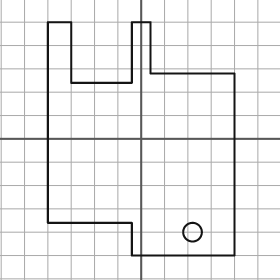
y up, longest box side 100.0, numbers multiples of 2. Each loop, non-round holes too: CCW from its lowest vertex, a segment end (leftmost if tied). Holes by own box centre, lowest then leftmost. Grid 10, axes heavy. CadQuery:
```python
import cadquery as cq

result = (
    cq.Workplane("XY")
    .moveTo(-4.0, -50.0)
    .lineTo(40.0, -50.0)
    .lineTo(40.0, 28.0)
    .lineTo(4.0, 28.0)
    .lineTo(4.0, 50.0)
    .lineTo(-4.0, 50.0)
    .lineTo(-4.0, 24.0)
    .lineTo(-30.0, 24.0)
    .lineTo(-30.0, 50.0)
    .lineTo(-40.0, 50.0)
    .lineTo(-40.0, -36.0)
    .lineTo(-4.0, -36.0)
    .close()
    .moveTo(22.0, -40.0)
    .circle(4.0)
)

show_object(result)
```